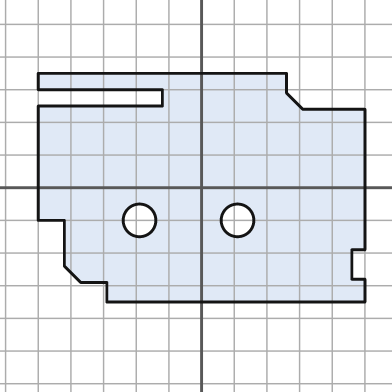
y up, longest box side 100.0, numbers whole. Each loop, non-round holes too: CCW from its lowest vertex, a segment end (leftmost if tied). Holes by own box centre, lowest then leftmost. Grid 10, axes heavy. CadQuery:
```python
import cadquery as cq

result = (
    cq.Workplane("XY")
    .moveTo(-29.0, -35.0)
    .lineTo(50.0, -35.0)
    .lineTo(50.0, -28.0)
    .lineTo(46.0, -28.0)
    .lineTo(46.0, -19.0)
    .lineTo(50.0, -19.0)
    .lineTo(50.0, 24.0)
    .lineTo(31.0, 24.0)
    .lineTo(26.0, 29.0)
    .lineTo(26.0, 35.0)
    .lineTo(-50.0, 35.0)
    .lineTo(-50.0, 30.0)
    .lineTo(-12.0, 30.0)
    .lineTo(-12.0, 25.0)
    .lineTo(-50.0, 25.0)
    .lineTo(-50.0, -10.0)
    .lineTo(-42.0, -10.0)
    .lineTo(-42.0, -24.0)
    .lineTo(-37.0, -29.0)
    .lineTo(-29.0, -29.0)
    .close()
    .moveTo(-19.0, -10.0)
    .circle(5.0)
    .moveTo(11.0, -10.0)
    .circle(5.0)
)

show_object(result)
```